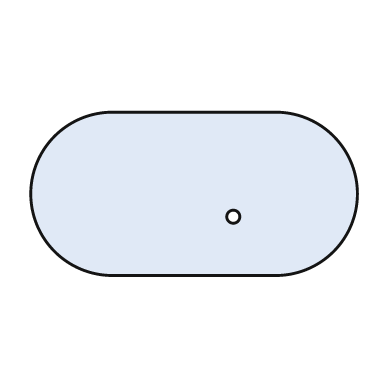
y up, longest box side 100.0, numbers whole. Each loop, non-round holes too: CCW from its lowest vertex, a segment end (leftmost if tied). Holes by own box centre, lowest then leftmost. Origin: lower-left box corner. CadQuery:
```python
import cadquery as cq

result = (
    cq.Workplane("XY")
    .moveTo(25.0, 0.0)
    .lineTo(75.0, 0.0)
    .threePointArc((100.0, 25.0), (75.0, 50.0))
    .lineTo(25.0, 50.0)
    .threePointArc((0.0, 25.0), (25.0, 0.0))
    .close()
    .moveTo(62.0, 18.0)
    .circle(2.0)
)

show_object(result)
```